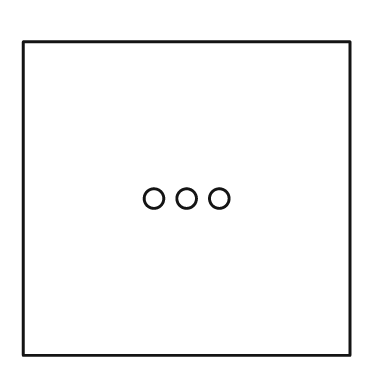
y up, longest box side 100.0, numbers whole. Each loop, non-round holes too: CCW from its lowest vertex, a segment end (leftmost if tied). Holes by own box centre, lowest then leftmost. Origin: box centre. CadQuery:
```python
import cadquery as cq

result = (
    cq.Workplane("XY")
    .moveTo(-50.0, -48.0)
    .lineTo(50.0, -48.0)
    .lineTo(50.0, 48.0)
    .lineTo(-50.0, 48.0)
    .close()
    .moveTo(-10.0, 0.0)
    .circle(3.0)
    .moveTo(0.0, 0.0)
    .circle(3.0)
    .moveTo(10.0, 0.0)
    .circle(3.0)
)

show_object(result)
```